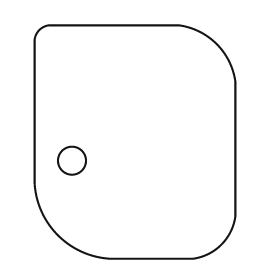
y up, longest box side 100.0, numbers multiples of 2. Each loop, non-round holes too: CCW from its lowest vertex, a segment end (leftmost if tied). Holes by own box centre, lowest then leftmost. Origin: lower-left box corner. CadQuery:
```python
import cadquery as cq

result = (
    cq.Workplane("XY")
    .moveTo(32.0, 0.0)
    .lineTo(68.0, 0.0)
    .threePointArc((80.0, 6.0), (86.0, 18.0))
    .lineTo(86.0, 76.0)
    .threePointArc((78.0, 92.0), (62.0, 100.0))
    .lineTo(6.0, 100.0)
    .threePointArc((2.0, 98.0), (0.0, 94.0))
    .lineTo(0.0, 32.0)
    .threePointArc((10.0, 10.0), (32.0, 0.0))
    .close()
    .moveTo(16.0, 42.0)
    .circle(6.0)
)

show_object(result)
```